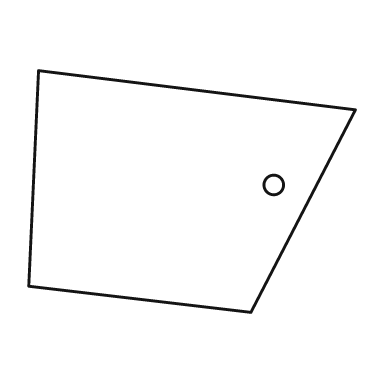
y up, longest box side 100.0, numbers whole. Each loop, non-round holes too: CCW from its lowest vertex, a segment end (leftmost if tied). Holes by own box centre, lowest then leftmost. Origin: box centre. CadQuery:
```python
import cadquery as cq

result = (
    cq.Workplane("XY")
    .moveTo(18.0, -37.0)
    .lineTo(50.0, 25.0)
    .lineTo(-47.0, 37.0)
    .lineTo(-50.0, -29.0)
    .close()
    .moveTo(25.0, 2.0)
    .circle(3.0)
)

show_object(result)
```